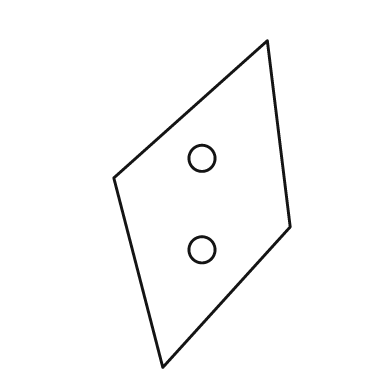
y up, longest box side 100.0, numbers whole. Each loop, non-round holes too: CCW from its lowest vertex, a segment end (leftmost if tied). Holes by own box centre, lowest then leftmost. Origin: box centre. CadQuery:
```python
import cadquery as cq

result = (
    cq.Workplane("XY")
    .moveTo(-12.0, -50.0)
    .lineTo(27.0, -7.0)
    .lineTo(20.0, 50.0)
    .lineTo(-27.0, 8.0)
    .close()
    .moveTo(0.0, -14.0)
    .circle(4.0)
    .moveTo(0.0, 14.0)
    .circle(4.0)
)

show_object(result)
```